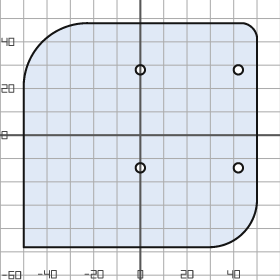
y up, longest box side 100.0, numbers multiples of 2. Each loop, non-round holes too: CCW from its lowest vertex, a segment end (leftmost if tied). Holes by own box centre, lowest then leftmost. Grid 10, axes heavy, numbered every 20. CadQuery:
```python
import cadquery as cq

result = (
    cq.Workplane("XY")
    .moveTo(-50.0, -48.0)
    .lineTo(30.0, -48.0)
    .threePointArc((44.0, -42.0), (50.0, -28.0))
    .lineTo(50.0, 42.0)
    .threePointArc((48.0, 46.0), (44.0, 48.0))
    .lineTo(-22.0, 48.0)
    .threePointArc((-42.0, 40.0), (-50.0, 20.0))
    .close()
    .moveTo(0.0, -14.0)
    .circle(2.0)
    .moveTo(42.0, -14.0)
    .circle(2.0)
    .moveTo(0.0, 28.0)
    .circle(2.0)
    .moveTo(42.0, 28.0)
    .circle(2.0)
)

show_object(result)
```